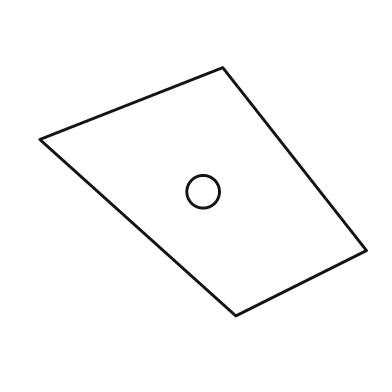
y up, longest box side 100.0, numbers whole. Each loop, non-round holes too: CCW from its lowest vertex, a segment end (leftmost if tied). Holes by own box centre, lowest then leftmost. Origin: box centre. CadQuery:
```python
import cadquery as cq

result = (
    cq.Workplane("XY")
    .moveTo(10.0, -38.0)
    .lineTo(50.0, -18.0)
    .lineTo(6.0, 38.0)
    .lineTo(-50.0, 16.0)
    .close()
    .moveTo(0.0, 0.0)
    .circle(5.0)
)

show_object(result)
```